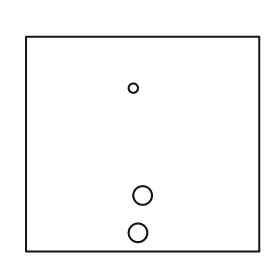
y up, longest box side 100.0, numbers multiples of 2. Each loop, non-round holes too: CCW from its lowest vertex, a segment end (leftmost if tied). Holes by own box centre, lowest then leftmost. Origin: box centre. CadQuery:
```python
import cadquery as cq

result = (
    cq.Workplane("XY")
    .moveTo(-50.0, -46.0)
    .lineTo(50.0, -46.0)
    .lineTo(50.0, 46.0)
    .lineTo(-50.0, 46.0)
    .close()
    .moveTo(-2.0, -38.0)
    .circle(4.0)
    .moveTo(0.0, -22.0)
    .circle(4.0)
    .moveTo(-4.0, 24.0)
    .circle(2.0)
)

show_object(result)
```